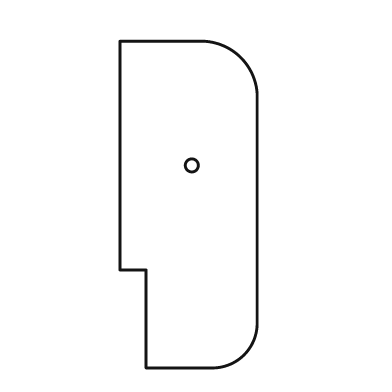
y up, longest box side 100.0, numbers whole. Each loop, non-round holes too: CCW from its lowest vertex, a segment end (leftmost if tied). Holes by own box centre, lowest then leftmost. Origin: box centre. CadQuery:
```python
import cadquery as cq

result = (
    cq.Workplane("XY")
    .moveTo(-13.0, -50.0)
    .lineTo(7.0, -50.0)
    .threePointArc((17.0, -46.0), (21.0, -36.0))
    .lineTo(21.0, 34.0)
    .threePointArc((16.0, 45.0), (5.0, 50.0))
    .lineTo(-21.0, 50.0)
    .lineTo(-21.0, -20.0)
    .lineTo(-13.0, -20.0)
    .close()
    .moveTo(1.0, 12.0)
    .circle(2.0)
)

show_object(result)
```